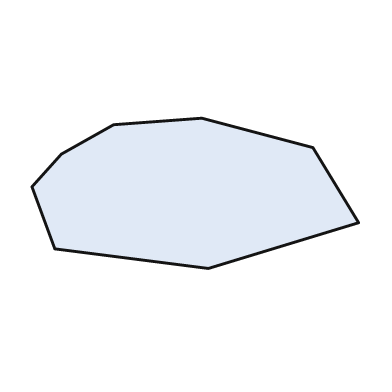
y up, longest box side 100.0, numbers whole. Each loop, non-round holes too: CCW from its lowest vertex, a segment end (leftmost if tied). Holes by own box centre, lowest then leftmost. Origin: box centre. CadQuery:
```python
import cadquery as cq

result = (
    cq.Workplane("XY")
    .moveTo(4.0, -23.0)
    .lineTo(50.0, -9.0)
    .lineTo(36.0, 14.0)
    .lineTo(2.0, 23.0)
    .lineTo(-25.0, 21.0)
    .lineTo(-41.0, 12.0)
    .lineTo(-50.0, 2.0)
    .lineTo(-43.0, -17.0)
    .close()
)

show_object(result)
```